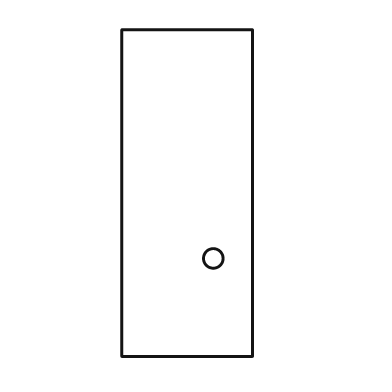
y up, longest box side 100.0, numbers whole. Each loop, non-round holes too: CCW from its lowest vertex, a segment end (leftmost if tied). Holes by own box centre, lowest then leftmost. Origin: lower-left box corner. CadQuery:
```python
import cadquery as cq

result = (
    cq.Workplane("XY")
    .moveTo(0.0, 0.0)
    .lineTo(40.0, 0.0)
    .lineTo(40.0, 100.0)
    .lineTo(0.0, 100.0)
    .close()
    .moveTo(28.0, 30.0)
    .circle(3.0)
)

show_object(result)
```